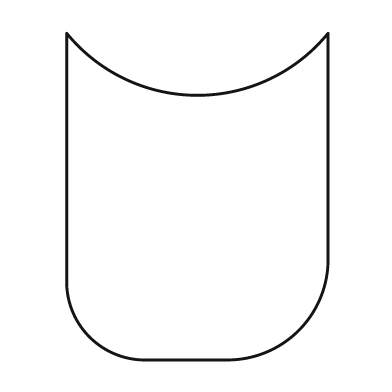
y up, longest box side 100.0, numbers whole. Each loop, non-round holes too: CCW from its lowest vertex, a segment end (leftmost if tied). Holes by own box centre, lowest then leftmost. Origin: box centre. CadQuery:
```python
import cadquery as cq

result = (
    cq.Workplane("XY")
    .moveTo(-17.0, -50.0)
    .lineTo(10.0, -50.0)
    .threePointArc((31.0, -41.0), (40.0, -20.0))
    .lineTo(40.0, 50.0)
    .threePointArc((0.0, 31.0), (-40.0, 50.0))
    .lineTo(-40.0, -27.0)
    .threePointArc((-33.0, -43.0), (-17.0, -50.0))
    .close()
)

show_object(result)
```